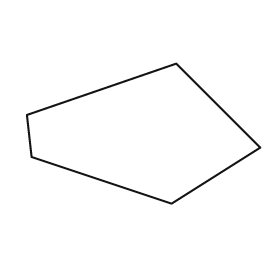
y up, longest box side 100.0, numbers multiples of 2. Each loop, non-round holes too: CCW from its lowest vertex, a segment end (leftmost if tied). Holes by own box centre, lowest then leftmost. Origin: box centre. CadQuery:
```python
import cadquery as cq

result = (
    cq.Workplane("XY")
    .moveTo(12.0, -30.0)
    .lineTo(50.0, -6.0)
    .lineTo(14.0, 30.0)
    .lineTo(-50.0, 8.0)
    .lineTo(-48.0, -10.0)
    .close()
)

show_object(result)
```